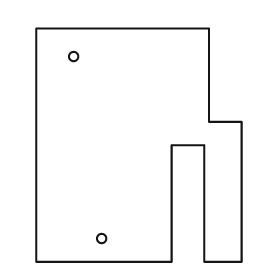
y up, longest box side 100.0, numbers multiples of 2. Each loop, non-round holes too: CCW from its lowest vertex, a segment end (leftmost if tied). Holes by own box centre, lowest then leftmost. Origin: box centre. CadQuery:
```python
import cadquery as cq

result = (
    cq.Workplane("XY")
    .moveTo(-44.0, -50.0)
    .lineTo(14.0, -50.0)
    .lineTo(14.0, 0.0)
    .lineTo(28.0, 0.0)
    .lineTo(28.0, -50.0)
    .lineTo(44.0, -50.0)
    .lineTo(44.0, 10.0)
    .lineTo(30.0, 10.0)
    .lineTo(30.0, 50.0)
    .lineTo(-44.0, 50.0)
    .close()
    .moveTo(-16.0, -40.0)
    .circle(2.0)
    .moveTo(-28.0, 38.0)
    .circle(2.0)
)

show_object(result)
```